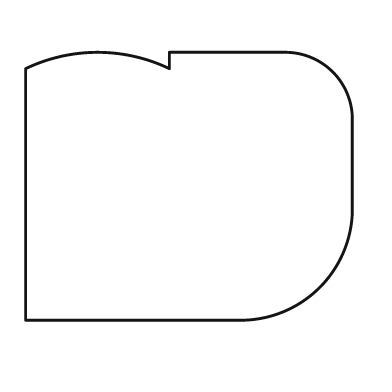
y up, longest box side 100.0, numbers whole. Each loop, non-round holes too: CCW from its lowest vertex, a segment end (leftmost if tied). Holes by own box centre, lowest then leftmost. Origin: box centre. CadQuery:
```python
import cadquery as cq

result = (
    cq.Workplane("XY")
    .moveTo(-50.0, -41.0)
    .lineTo(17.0, -41.0)
    .threePointArc((40.0, -31.0), (50.0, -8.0))
    .lineTo(50.0, 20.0)
    .threePointArc((44.0, 35.0), (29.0, 41.0))
    .lineTo(-6.0, 41.0)
    .lineTo(-6.0, 36.0)
    .threePointArc((-28.0, 41.0), (-50.0, 36.0))
    .close()
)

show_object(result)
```